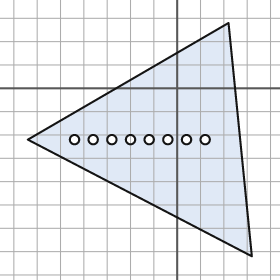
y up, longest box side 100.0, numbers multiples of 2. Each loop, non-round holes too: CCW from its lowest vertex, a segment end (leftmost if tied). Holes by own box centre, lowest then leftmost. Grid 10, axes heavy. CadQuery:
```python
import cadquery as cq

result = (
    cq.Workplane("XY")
    .moveTo(32.0, -72.0)
    .lineTo(22.0, 28.0)
    .lineTo(-64.0, -22.0)
    .close()
    .moveTo(-44.0, -22.0)
    .circle(2.0)
    .moveTo(-36.0, -22.0)
    .circle(2.0)
    .moveTo(-28.0, -22.0)
    .circle(2.0)
    .moveTo(-20.0, -22.0)
    .circle(2.0)
    .moveTo(-12.0, -22.0)
    .circle(2.0)
    .moveTo(-4.0, -22.0)
    .circle(2.0)
    .moveTo(4.0, -22.0)
    .circle(2.0)
    .moveTo(12.0, -22.0)
    .circle(2.0)
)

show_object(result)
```